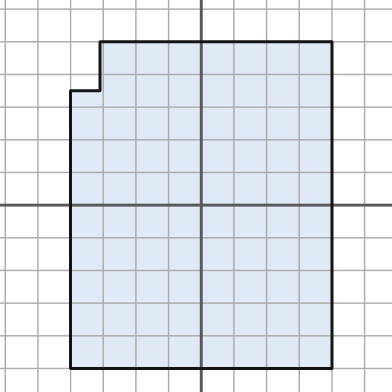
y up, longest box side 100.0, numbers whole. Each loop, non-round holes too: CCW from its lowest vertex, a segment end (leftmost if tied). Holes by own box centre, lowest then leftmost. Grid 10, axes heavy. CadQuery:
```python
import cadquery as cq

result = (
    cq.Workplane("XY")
    .moveTo(-40.0, -50.0)
    .lineTo(40.0, -50.0)
    .lineTo(40.0, 50.0)
    .lineTo(-31.0, 50.0)
    .lineTo(-31.0, 35.0)
    .lineTo(-40.0, 35.0)
    .close()
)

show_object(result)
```